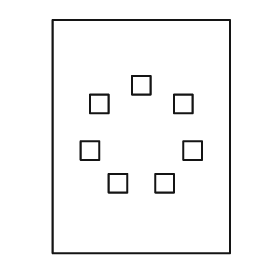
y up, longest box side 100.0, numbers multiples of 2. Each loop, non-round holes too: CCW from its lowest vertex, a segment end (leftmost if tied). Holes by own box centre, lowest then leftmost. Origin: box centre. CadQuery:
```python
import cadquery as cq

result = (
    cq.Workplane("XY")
    .moveTo(-38.0, -50.0)
    .lineTo(38.0, -50.0)
    .lineTo(38.0, 50.0)
    .lineTo(-38.0, 50.0)
    .close()
    .moveTo(-14.0, -24.0)
    .lineTo(-6.0, -24.0)
    .lineTo(-6.0, -16.0)
    .lineTo(-14.0, -16.0)
    .close()
    .moveTo(6.0, -24.0)
    .lineTo(14.0, -24.0)
    .lineTo(14.0, -16.0)
    .lineTo(6.0, -16.0)
    .close()
    .moveTo(-26.0, -10.0)
    .lineTo(-18.0, -10.0)
    .lineTo(-18.0, -2.0)
    .lineTo(-26.0, -2.0)
    .close()
    .moveTo(18.0, -10.0)
    .lineTo(26.0, -10.0)
    .lineTo(26.0, -2.0)
    .lineTo(18.0, -2.0)
    .close()
    .moveTo(-22.0, 10.0)
    .lineTo(-14.0, 10.0)
    .lineTo(-14.0, 18.0)
    .lineTo(-22.0, 18.0)
    .close()
    .moveTo(14.0, 10.0)
    .lineTo(22.0, 10.0)
    .lineTo(22.0, 18.0)
    .lineTo(14.0, 18.0)
    .close()
    .moveTo(-4.0, 18.0)
    .lineTo(4.0, 18.0)
    .lineTo(4.0, 26.0)
    .lineTo(-4.0, 26.0)
    .close()
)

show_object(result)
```